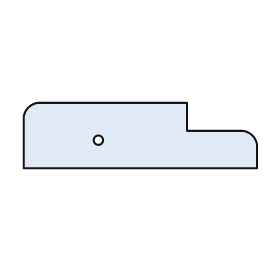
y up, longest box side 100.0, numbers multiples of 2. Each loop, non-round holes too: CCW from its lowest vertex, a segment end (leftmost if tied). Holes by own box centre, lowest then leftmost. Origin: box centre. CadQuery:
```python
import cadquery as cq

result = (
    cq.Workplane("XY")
    .moveTo(-50.0, -14.0)
    .lineTo(50.0, -14.0)
    .lineTo(50.0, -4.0)
    .threePointArc((48.0, 0.0), (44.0, 2.0))
    .lineTo(20.0, 2.0)
    .lineTo(20.0, 14.0)
    .lineTo(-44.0, 14.0)
    .threePointArc((-48.0, 12.0), (-50.0, 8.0))
    .close()
    .moveTo(-18.0, -2.0)
    .circle(2.0)
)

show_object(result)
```